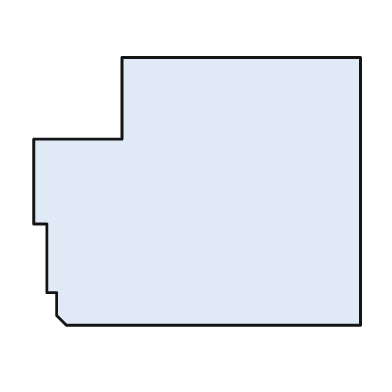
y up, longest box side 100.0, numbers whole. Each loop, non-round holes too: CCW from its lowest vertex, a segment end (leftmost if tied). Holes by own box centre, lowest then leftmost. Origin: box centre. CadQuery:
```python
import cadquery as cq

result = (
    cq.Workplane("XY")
    .moveTo(-40.0, -41.0)
    .lineTo(50.0, -41.0)
    .lineTo(50.0, 41.0)
    .lineTo(-23.0, 41.0)
    .lineTo(-23.0, 16.0)
    .lineTo(-50.0, 16.0)
    .lineTo(-50.0, -10.0)
    .lineTo(-46.0, -10.0)
    .lineTo(-46.0, -31.0)
    .lineTo(-43.0, -31.0)
    .lineTo(-43.0, -38.0)
    .close()
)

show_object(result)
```